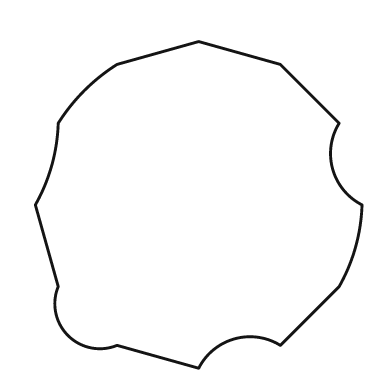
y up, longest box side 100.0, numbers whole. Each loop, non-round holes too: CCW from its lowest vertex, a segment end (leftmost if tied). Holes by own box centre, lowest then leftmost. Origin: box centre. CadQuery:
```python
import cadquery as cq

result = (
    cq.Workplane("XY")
    .moveTo(0.0, -50.0)
    .threePointArc((11.0, -41.0), (25.0, -43.0))
    .lineTo(43.0, -25.0)
    .threePointArc((48.0, -13.0), (50.0, 0.0))
    .threePointArc((41.0, 11.0), (43.0, 25.0))
    .lineTo(25.0, 43.0)
    .lineTo(0.0, 50.0)
    .lineTo(-25.0, 43.0)
    .threePointArc((-35.0, 35.0), (-43.0, 25.0))
    .threePointArc((-45.0, 12.0), (-50.0, 0.0))
    .lineTo(-43.0, -25.0)
    .threePointArc((-40.0, -40.0), (-25.0, -43.0))
    .close()
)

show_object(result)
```